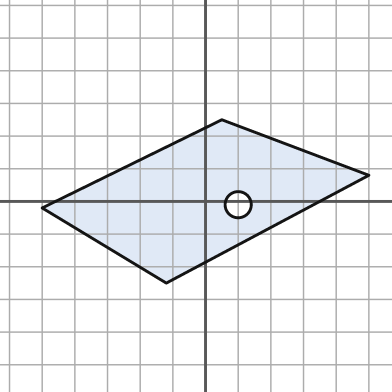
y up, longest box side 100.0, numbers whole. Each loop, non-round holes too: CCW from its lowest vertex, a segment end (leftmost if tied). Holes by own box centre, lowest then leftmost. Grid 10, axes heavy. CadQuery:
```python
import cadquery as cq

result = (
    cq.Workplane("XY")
    .moveTo(-12.0, -25.0)
    .lineTo(50.0, 8.0)
    .lineTo(5.0, 25.0)
    .lineTo(-50.0, -2.0)
    .close()
    .moveTo(10.0, -1.0)
    .circle(4.0)
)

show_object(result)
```